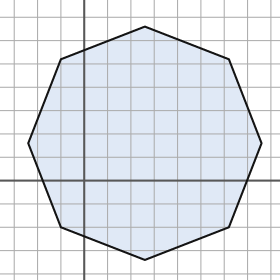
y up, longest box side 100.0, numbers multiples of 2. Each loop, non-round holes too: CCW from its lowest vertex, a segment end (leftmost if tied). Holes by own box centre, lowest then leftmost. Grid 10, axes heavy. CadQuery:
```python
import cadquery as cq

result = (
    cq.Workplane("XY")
    .moveTo(26.0, -34.0)
    .lineTo(62.0, -20.0)
    .lineTo(76.0, 16.0)
    .lineTo(62.0, 52.0)
    .lineTo(26.0, 66.0)
    .lineTo(-10.0, 52.0)
    .lineTo(-24.0, 16.0)
    .lineTo(-10.0, -20.0)
    .close()
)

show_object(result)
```